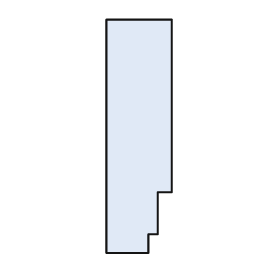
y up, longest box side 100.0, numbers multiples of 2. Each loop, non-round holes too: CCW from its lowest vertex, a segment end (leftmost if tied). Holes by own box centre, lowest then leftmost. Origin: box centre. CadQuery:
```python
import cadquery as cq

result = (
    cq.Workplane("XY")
    .moveTo(-14.0, -50.0)
    .lineTo(4.0, -50.0)
    .lineTo(4.0, -42.0)
    .lineTo(8.0, -42.0)
    .lineTo(8.0, -24.0)
    .lineTo(14.0, -24.0)
    .lineTo(14.0, 50.0)
    .lineTo(-14.0, 50.0)
    .close()
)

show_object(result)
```